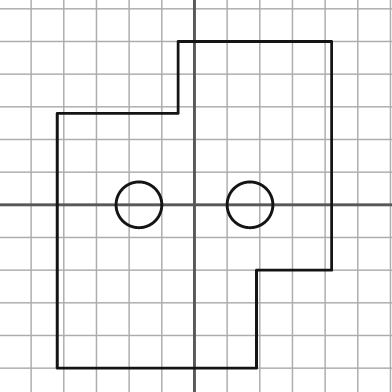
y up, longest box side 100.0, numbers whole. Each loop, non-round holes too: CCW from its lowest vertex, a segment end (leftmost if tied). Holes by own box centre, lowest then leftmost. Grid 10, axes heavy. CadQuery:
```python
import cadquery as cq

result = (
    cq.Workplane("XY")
    .moveTo(-42.0, -50.0)
    .lineTo(19.0, -50.0)
    .lineTo(19.0, -20.0)
    .lineTo(42.0, -20.0)
    .lineTo(42.0, 50.0)
    .lineTo(-5.0, 50.0)
    .lineTo(-5.0, 28.0)
    .lineTo(-42.0, 28.0)
    .close()
    .moveTo(-17.0, 0.0)
    .circle(7.0)
    .moveTo(17.0, 0.0)
    .circle(7.0)
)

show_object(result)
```